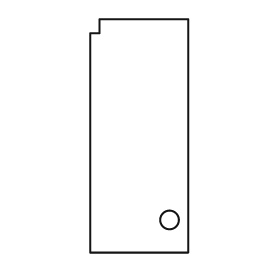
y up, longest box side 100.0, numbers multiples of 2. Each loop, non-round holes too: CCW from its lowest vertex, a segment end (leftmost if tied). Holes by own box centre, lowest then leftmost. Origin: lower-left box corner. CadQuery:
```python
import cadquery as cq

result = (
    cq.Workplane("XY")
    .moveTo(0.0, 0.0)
    .lineTo(42.0, 0.0)
    .lineTo(42.0, 100.0)
    .lineTo(4.0, 100.0)
    .lineTo(4.0, 94.0)
    .lineTo(0.0, 94.0)
    .close()
    .moveTo(34.0, 14.0)
    .circle(4.0)
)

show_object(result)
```